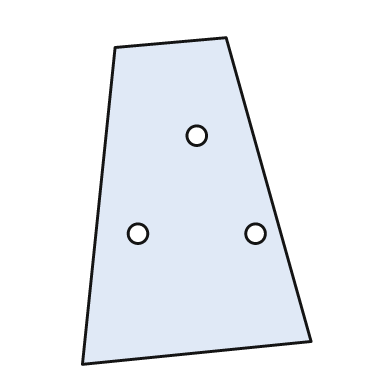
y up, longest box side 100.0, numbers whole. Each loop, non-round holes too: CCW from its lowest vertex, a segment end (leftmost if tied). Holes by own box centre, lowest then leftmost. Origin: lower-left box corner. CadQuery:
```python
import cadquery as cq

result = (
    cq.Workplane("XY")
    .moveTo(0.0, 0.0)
    .lineTo(70.0, 7.0)
    .lineTo(44.0, 100.0)
    .lineTo(10.0, 97.0)
    .close()
    .moveTo(17.0, 40.0)
    .circle(3.0)
    .moveTo(53.0, 40.0)
    .circle(3.0)
    .moveTo(35.0, 70.0)
    .circle(3.0)
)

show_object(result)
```